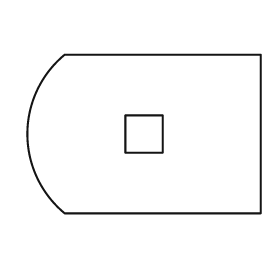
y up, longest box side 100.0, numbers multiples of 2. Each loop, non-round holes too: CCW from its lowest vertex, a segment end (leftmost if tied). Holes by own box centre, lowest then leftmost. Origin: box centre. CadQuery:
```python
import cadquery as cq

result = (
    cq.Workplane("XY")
    .moveTo(-34.0, -34.0)
    .lineTo(50.0, -34.0)
    .lineTo(50.0, 34.0)
    .lineTo(-34.0, 34.0)
    .threePointArc((-50.0, 0.0), (-34.0, -34.0))
    .close()
    .moveTo(-8.0, -8.0)
    .lineTo(8.0, -8.0)
    .lineTo(8.0, 8.0)
    .lineTo(-8.0, 8.0)
    .close()
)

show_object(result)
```